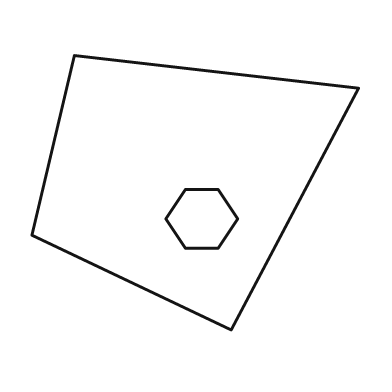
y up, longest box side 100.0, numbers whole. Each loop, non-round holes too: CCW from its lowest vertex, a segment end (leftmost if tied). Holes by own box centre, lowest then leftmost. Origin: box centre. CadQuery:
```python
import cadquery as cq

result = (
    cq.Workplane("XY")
    .moveTo(11.0, -42.0)
    .lineTo(50.0, 32.0)
    .lineTo(-37.0, 42.0)
    .lineTo(-50.0, -13.0)
    .close()
    .moveTo(-3.0, -17.0)
    .lineTo(7.0, -17.0)
    .lineTo(13.0, -8.0)
    .lineTo(7.0, 1.0)
    .lineTo(-3.0, 1.0)
    .lineTo(-9.0, -8.0)
    .close()
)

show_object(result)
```